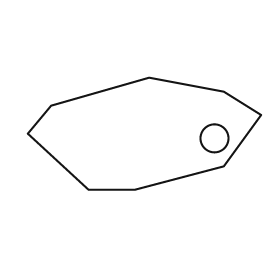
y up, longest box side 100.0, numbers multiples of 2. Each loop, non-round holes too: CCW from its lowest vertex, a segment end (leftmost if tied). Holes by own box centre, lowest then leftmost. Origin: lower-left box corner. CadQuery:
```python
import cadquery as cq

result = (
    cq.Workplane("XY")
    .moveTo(26.0, 0.0)
    .lineTo(46.0, 0.0)
    .lineTo(84.0, 10.0)
    .lineTo(100.0, 32.0)
    .lineTo(84.0, 42.0)
    .lineTo(52.0, 48.0)
    .lineTo(10.0, 36.0)
    .lineTo(0.0, 24.0)
    .close()
    .moveTo(80.0, 22.0)
    .circle(6.0)
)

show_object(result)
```